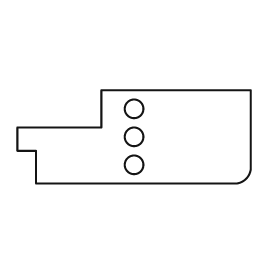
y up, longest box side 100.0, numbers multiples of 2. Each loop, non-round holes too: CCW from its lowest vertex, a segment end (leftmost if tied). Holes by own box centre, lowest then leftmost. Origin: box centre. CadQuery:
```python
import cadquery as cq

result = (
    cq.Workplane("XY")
    .moveTo(-42.0, -20.0)
    .lineTo(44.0, -20.0)
    .threePointArc((48.0, -18.0), (50.0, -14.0))
    .lineTo(50.0, 20.0)
    .lineTo(-14.0, 20.0)
    .lineTo(-14.0, 4.0)
    .lineTo(-50.0, 4.0)
    .lineTo(-50.0, -6.0)
    .lineTo(-42.0, -6.0)
    .close()
    .moveTo(0.0, -12.0)
    .circle(4.0)
    .moveTo(0.0, 0.0)
    .circle(4.0)
    .moveTo(0.0, 12.0)
    .circle(4.0)
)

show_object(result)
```